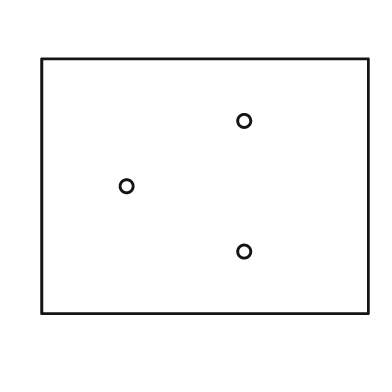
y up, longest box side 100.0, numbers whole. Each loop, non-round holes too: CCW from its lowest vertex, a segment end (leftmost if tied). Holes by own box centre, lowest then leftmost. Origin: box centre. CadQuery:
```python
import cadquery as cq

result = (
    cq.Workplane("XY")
    .moveTo(-50.0, -39.0)
    .lineTo(50.0, -39.0)
    .lineTo(50.0, 39.0)
    .lineTo(-50.0, 39.0)
    .close()
    .moveTo(12.0, -20.0)
    .circle(2.0)
    .moveTo(-24.0, 0.0)
    .circle(2.0)
    .moveTo(12.0, 20.0)
    .circle(2.0)
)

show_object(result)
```